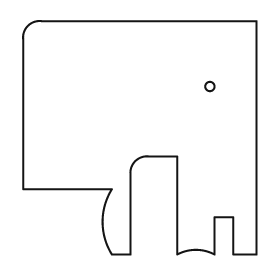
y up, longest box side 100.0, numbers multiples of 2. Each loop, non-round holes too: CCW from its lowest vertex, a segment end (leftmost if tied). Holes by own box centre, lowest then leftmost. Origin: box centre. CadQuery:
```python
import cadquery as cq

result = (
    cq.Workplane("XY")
    .moveTo(-12.0, -50.0)
    .lineTo(-4.0, -50.0)
    .lineTo(-4.0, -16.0)
    .threePointArc((-2.0, -10.0), (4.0, -8.0))
    .lineTo(16.0, -8.0)
    .lineTo(16.0, -50.0)
    .threePointArc((24.0, -48.0), (32.0, -50.0))
    .lineTo(32.0, -34.0)
    .lineTo(40.0, -34.0)
    .lineTo(40.0, -50.0)
    .lineTo(50.0, -50.0)
    .lineTo(50.0, 50.0)
    .lineTo(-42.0, 50.0)
    .threePointArc((-48.0, 48.0), (-50.0, 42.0))
    .lineTo(-50.0, -22.0)
    .lineTo(-12.0, -22.0)
    .threePointArc((-16.0, -36.0), (-12.0, -50.0))
    .close()
    .moveTo(30.0, 22.0)
    .circle(2.0)
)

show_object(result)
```